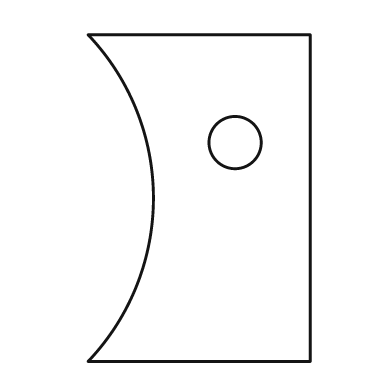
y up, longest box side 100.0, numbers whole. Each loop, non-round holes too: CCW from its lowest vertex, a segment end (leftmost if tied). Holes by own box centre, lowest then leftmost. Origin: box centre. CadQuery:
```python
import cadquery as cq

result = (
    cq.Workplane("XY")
    .moveTo(-34.0, -50.0)
    .lineTo(34.0, -50.0)
    .lineTo(34.0, 50.0)
    .lineTo(-34.0, 50.0)
    .threePointArc((-14.0, 0.0), (-34.0, -50.0))
    .close()
    .moveTo(11.0, 17.0)
    .circle(8.0)
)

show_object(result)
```